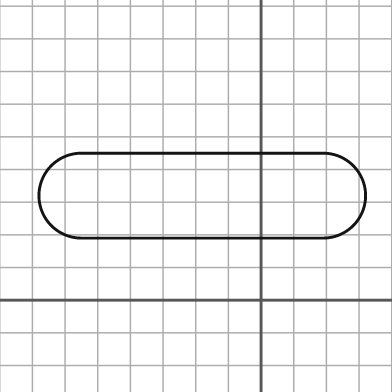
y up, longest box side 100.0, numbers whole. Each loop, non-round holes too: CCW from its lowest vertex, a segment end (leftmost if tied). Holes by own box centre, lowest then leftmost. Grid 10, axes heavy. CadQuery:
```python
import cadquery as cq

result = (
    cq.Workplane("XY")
    .moveTo(-55.0, 19.0)
    .lineTo(19.0, 19.0)
    .threePointArc((32.0, 32.0), (19.0, 45.0))
    .lineTo(-55.0, 45.0)
    .threePointArc((-68.0, 32.0), (-55.0, 19.0))
    .close()
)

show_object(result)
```